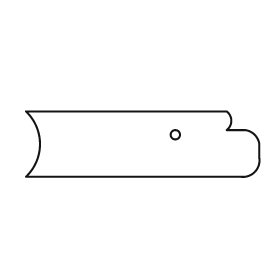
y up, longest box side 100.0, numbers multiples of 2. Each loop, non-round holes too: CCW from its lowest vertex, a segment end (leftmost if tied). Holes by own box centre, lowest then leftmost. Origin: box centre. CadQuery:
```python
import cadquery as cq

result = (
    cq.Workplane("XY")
    .moveTo(-50.0, -14.0)
    .lineTo(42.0, -14.0)
    .threePointArc((48.0, -12.0), (50.0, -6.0))
    .lineTo(50.0, 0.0)
    .threePointArc((48.0, 4.0), (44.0, 6.0))
    .lineTo(36.0, 6.0)
    .threePointArc((38.0, 10.0), (36.0, 14.0))
    .lineTo(-50.0, 14.0)
    .threePointArc((-44.0, 0.0), (-50.0, -14.0))
    .close()
    .moveTo(14.0, 4.0)
    .circle(2.0)
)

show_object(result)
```